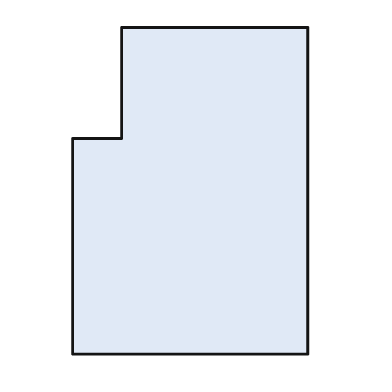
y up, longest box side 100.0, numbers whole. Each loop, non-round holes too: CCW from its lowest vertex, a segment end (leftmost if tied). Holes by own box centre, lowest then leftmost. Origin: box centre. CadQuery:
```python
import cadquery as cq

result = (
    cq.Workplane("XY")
    .moveTo(-36.0, -50.0)
    .lineTo(36.0, -50.0)
    .lineTo(36.0, 50.0)
    .lineTo(-21.0, 50.0)
    .lineTo(-21.0, 16.0)
    .lineTo(-36.0, 16.0)
    .close()
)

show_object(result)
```